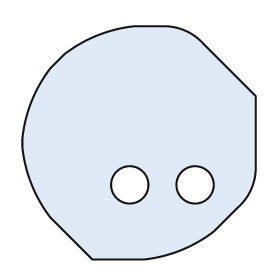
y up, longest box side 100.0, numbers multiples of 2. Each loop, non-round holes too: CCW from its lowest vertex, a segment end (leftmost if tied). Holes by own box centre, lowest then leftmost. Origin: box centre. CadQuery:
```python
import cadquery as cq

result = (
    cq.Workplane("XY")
    .moveTo(-20.0, -50.0)
    .lineTo(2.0, -50.0)
    .threePointArc((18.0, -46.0), (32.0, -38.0))
    .lineTo(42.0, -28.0)
    .threePointArc((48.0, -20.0), (50.0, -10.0))
    .lineTo(50.0, 20.0)
    .lineTo(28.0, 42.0)
    .threePointArc((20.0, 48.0), (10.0, 50.0))
    .lineTo(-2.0, 50.0)
    .threePointArc((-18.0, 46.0), (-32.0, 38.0))
    .lineTo(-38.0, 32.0)
    .threePointArc((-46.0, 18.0), (-50.0, 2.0))
    .lineTo(-50.0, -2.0)
    .threePointArc((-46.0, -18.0), (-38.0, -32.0))
    .close()
    .moveTo(-4.0, -18.0)
    .circle(8.0)
    .moveTo(24.0, -18.0)
    .circle(8.0)
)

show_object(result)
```